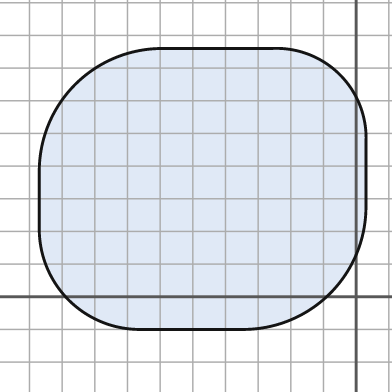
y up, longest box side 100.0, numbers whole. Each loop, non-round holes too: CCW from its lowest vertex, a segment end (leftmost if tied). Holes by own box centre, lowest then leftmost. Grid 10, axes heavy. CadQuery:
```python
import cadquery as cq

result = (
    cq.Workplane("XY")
    .moveTo(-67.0, -10.0)
    .lineTo(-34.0, -10.0)
    .threePointArc((-8.0, 1.0), (3.0, 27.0))
    .lineTo(3.0, 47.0)
    .threePointArc((-5.0, 68.0), (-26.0, 76.0))
    .lineTo(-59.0, 76.0)
    .threePointArc((-86.0, 65.0), (-97.0, 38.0))
    .lineTo(-97.0, 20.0)
    .threePointArc((-88.0, -1.0), (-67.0, -10.0))
    .close()
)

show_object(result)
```